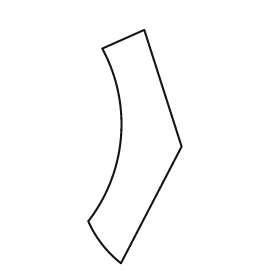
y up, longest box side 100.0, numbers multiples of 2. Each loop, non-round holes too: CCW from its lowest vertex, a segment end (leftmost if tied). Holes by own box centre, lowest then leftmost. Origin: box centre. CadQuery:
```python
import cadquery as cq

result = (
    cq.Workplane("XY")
    .moveTo(-6.0, -50.0)
    .lineTo(20.0, 0.0)
    .lineTo(4.0, 50.0)
    .lineTo(-14.0, 42.0)
    .threePointArc((-6.0, 4.0), (-20.0, -32.0))
    .threePointArc((-14.0, -42.0), (-6.0, -50.0))
    .close()
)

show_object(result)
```